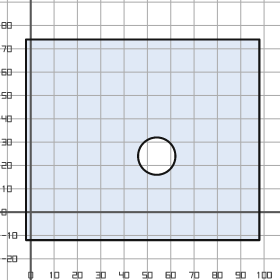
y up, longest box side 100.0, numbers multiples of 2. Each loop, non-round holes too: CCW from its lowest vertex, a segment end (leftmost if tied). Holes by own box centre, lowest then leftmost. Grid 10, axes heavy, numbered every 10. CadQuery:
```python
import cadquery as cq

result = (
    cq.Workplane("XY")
    .moveTo(-2.0, -12.0)
    .lineTo(98.0, -12.0)
    .lineTo(98.0, 74.0)
    .lineTo(-2.0, 74.0)
    .close()
    .moveTo(54.0, 24.0)
    .circle(8.0)
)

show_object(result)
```